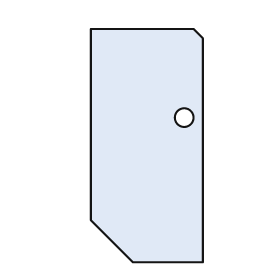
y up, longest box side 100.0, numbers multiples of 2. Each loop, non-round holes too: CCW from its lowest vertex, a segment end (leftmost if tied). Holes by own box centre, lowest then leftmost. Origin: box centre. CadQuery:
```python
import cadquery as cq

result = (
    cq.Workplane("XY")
    .moveTo(-6.0, -50.0)
    .lineTo(24.0, -50.0)
    .lineTo(24.0, 46.0)
    .lineTo(20.0, 50.0)
    .lineTo(-24.0, 50.0)
    .lineTo(-24.0, -32.0)
    .close()
    .moveTo(16.0, 12.0)
    .circle(4.0)
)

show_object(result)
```